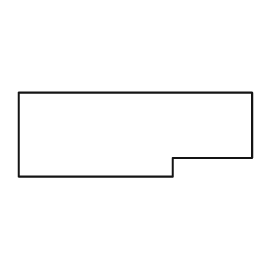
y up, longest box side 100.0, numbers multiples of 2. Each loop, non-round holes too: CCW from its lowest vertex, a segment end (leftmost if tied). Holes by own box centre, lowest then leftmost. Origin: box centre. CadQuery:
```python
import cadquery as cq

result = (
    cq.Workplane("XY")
    .moveTo(-50.0, -18.0)
    .lineTo(16.0, -18.0)
    .lineTo(16.0, -10.0)
    .lineTo(50.0, -10.0)
    .lineTo(50.0, 18.0)
    .lineTo(-50.0, 18.0)
    .close()
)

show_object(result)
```